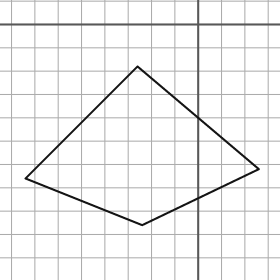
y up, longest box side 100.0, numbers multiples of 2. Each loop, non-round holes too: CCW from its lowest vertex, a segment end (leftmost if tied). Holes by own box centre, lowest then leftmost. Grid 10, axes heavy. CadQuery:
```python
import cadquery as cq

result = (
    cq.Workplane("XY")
    .moveTo(-24.0, -86.0)
    .lineTo(26.0, -62.0)
    .lineTo(-26.0, -18.0)
    .lineTo(-74.0, -66.0)
    .close()
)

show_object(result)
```